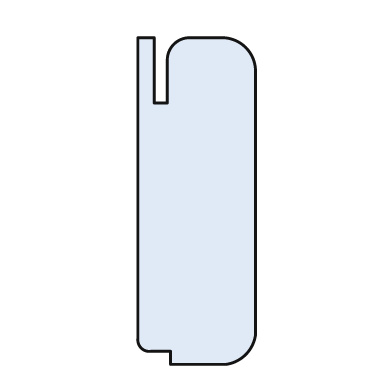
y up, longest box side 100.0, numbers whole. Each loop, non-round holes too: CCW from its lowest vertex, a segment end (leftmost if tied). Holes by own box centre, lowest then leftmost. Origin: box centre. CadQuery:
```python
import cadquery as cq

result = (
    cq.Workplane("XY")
    .moveTo(-8.0, -50.0)
    .lineTo(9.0, -50.0)
    .threePointArc((15.0, -47.0), (18.0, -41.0))
    .lineTo(18.0, 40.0)
    .threePointArc((15.0, 47.0), (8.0, 50.0))
    .lineTo(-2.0, 50.0)
    .threePointArc((-7.0, 48.0), (-9.0, 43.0))
    .lineTo(-9.0, 30.0)
    .lineTo(-13.0, 30.0)
    .lineTo(-13.0, 50.0)
    .lineTo(-18.0, 50.0)
    .lineTo(-18.0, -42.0)
    .threePointArc((-17.0, -45.0), (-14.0, -46.0))
    .lineTo(-8.0, -46.0)
    .close()
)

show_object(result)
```